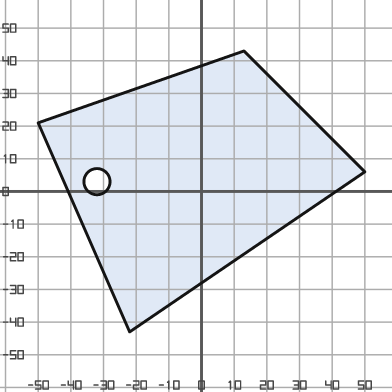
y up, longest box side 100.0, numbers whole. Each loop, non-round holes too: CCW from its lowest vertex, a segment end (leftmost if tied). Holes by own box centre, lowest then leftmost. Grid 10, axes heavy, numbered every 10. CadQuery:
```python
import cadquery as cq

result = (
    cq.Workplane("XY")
    .moveTo(-22.0, -43.0)
    .lineTo(50.0, 6.0)
    .lineTo(13.0, 43.0)
    .lineTo(-50.0, 21.0)
    .close()
    .moveTo(-32.0, 3.0)
    .circle(4.0)
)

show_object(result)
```